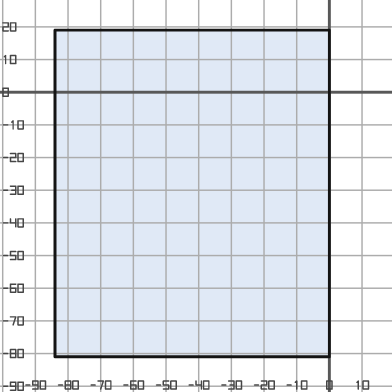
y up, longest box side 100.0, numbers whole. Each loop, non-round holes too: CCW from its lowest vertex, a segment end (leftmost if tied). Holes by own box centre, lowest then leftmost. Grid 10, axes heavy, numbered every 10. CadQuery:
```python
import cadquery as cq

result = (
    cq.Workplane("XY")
    .moveTo(-84.0, -81.0)
    .lineTo(0.0, -81.0)
    .lineTo(0.0, 19.0)
    .lineTo(-84.0, 19.0)
    .close()
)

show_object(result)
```